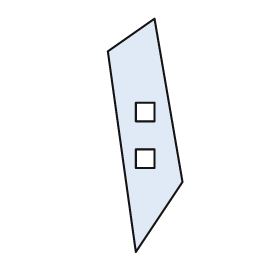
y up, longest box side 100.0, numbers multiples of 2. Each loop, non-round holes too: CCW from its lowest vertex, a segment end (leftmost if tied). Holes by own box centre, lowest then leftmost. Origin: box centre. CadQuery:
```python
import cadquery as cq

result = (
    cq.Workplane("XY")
    .moveTo(-4.0, -50.0)
    .lineTo(16.0, -20.0)
    .lineTo(4.0, 50.0)
    .lineTo(-16.0, 36.0)
    .close()
    .moveTo(-4.0, -14.0)
    .lineTo(4.0, -14.0)
    .lineTo(4.0, -6.0)
    .lineTo(-4.0, -6.0)
    .close()
    .moveTo(-4.0, 6.0)
    .lineTo(4.0, 6.0)
    .lineTo(4.0, 14.0)
    .lineTo(-4.0, 14.0)
    .close()
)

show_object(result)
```